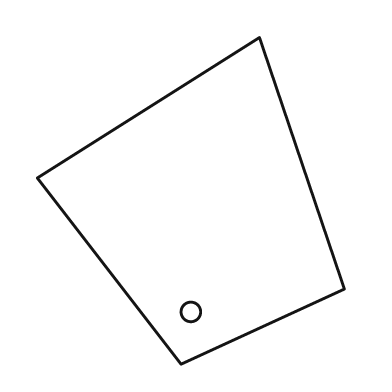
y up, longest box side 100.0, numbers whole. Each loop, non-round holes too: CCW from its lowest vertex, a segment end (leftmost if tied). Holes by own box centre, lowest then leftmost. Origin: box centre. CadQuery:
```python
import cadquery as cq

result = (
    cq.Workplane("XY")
    .moveTo(-3.0, -50.0)
    .lineTo(47.0, -27.0)
    .lineTo(21.0, 50.0)
    .lineTo(-47.0, 7.0)
    .close()
    .moveTo(0.0, -34.0)
    .circle(3.0)
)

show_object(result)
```